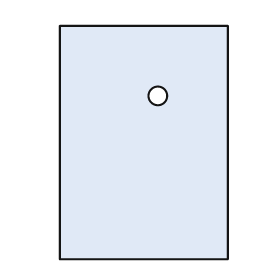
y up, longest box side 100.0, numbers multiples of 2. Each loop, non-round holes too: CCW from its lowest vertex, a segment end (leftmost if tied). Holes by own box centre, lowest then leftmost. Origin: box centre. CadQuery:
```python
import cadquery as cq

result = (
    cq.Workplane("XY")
    .moveTo(-36.0, -50.0)
    .lineTo(36.0, -50.0)
    .lineTo(36.0, 50.0)
    .lineTo(-36.0, 50.0)
    .close()
    .moveTo(6.0, 20.0)
    .circle(4.0)
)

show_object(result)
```